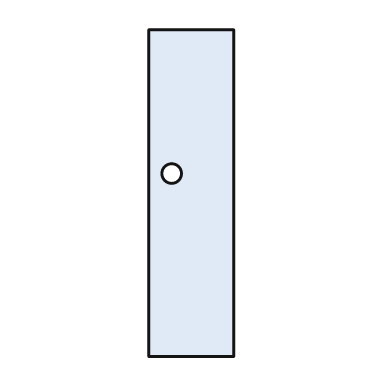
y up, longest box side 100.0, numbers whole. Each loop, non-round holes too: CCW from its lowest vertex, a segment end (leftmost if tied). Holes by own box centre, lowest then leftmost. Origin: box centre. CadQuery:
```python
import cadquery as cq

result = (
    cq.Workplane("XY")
    .moveTo(-13.0, -50.0)
    .lineTo(13.0, -50.0)
    .lineTo(13.0, 50.0)
    .lineTo(-13.0, 50.0)
    .close()
    .moveTo(-6.0, 6.0)
    .circle(3.0)
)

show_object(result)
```